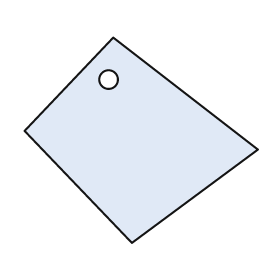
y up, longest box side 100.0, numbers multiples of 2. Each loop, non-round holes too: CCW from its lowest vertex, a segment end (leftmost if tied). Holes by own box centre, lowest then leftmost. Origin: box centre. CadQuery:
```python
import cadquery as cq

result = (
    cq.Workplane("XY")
    .moveTo(-4.0, -44.0)
    .lineTo(50.0, -4.0)
    .lineTo(-12.0, 44.0)
    .lineTo(-50.0, 4.0)
    .close()
    .moveTo(-14.0, 26.0)
    .circle(4.0)
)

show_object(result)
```